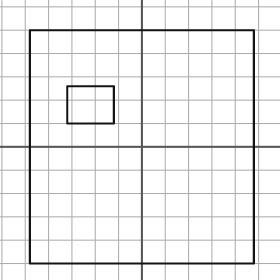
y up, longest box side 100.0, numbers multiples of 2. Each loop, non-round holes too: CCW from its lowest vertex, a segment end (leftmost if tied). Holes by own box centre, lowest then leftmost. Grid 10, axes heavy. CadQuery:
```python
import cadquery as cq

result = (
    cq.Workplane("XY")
    .moveTo(-48.0, -50.0)
    .lineTo(48.0, -50.0)
    .lineTo(48.0, 50.0)
    .lineTo(-48.0, 50.0)
    .close()
    .moveTo(-32.0, 10.0)
    .lineTo(-12.0, 10.0)
    .lineTo(-12.0, 26.0)
    .lineTo(-32.0, 26.0)
    .close()
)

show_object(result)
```